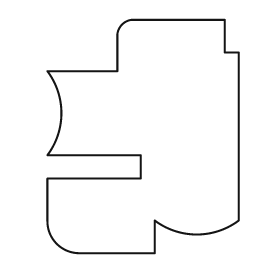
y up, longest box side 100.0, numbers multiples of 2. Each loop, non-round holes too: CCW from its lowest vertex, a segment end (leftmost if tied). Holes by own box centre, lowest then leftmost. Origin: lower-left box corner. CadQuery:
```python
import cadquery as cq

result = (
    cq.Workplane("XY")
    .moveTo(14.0, 0.0)
    .lineTo(46.0, 0.0)
    .lineTo(46.0, 14.0)
    .threePointArc((64.0, 8.0), (82.0, 14.0))
    .lineTo(82.0, 86.0)
    .lineTo(76.0, 86.0)
    .lineTo(76.0, 100.0)
    .lineTo(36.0, 100.0)
    .threePointArc((32.0, 98.0), (30.0, 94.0))
    .lineTo(30.0, 78.0)
    .lineTo(0.0, 78.0)
    .threePointArc((6.0, 60.0), (0.0, 42.0))
    .lineTo(40.0, 42.0)
    .lineTo(40.0, 32.0)
    .lineTo(0.0, 32.0)
    .lineTo(0.0, 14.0)
    .threePointArc((4.0, 4.0), (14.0, 0.0))
    .close()
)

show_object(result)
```